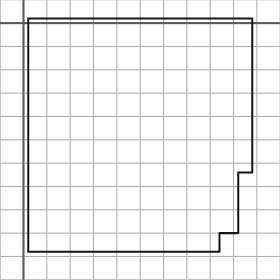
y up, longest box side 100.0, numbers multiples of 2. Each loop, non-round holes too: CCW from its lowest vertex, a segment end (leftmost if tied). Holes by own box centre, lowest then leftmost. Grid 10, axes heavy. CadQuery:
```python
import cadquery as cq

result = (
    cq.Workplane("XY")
    .moveTo(2.0, -98.0)
    .lineTo(84.0, -98.0)
    .lineTo(84.0, -90.0)
    .lineTo(92.0, -90.0)
    .lineTo(92.0, -64.0)
    .lineTo(98.0, -64.0)
    .lineTo(98.0, 2.0)
    .lineTo(2.0, 2.0)
    .close()
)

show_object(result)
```